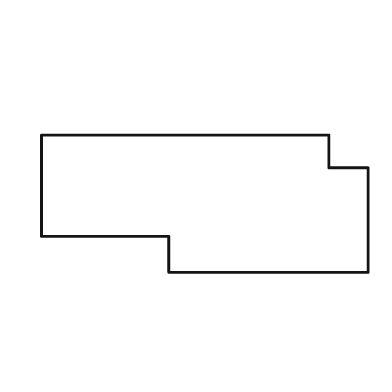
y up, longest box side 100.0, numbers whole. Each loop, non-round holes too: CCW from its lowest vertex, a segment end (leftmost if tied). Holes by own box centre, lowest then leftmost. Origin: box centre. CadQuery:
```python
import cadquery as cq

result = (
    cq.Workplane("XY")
    .moveTo(-11.0, -21.0)
    .lineTo(50.0, -21.0)
    .lineTo(50.0, 11.0)
    .lineTo(38.0, 11.0)
    .lineTo(38.0, 21.0)
    .lineTo(-50.0, 21.0)
    .lineTo(-50.0, -10.0)
    .lineTo(-11.0, -10.0)
    .close()
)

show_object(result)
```